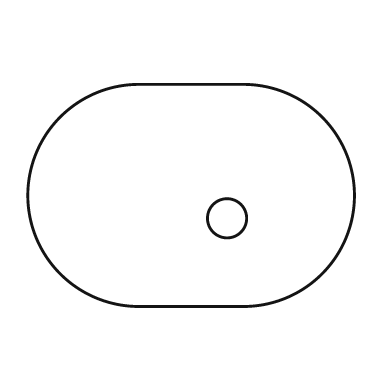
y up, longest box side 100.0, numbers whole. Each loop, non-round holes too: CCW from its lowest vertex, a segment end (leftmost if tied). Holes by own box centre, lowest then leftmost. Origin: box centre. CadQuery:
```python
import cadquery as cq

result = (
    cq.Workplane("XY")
    .moveTo(-16.0, -34.0)
    .lineTo(16.0, -34.0)
    .threePointArc((50.0, 0.0), (16.0, 34.0))
    .lineTo(-16.0, 34.0)
    .threePointArc((-50.0, 0.0), (-16.0, -34.0))
    .close()
    .moveTo(11.0, -7.0)
    .circle(6.0)
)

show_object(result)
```